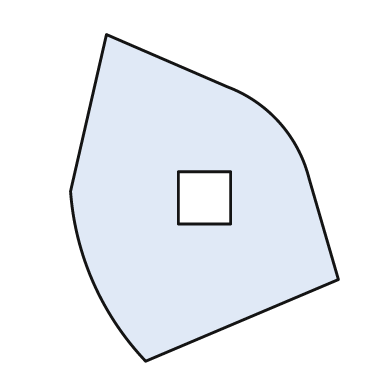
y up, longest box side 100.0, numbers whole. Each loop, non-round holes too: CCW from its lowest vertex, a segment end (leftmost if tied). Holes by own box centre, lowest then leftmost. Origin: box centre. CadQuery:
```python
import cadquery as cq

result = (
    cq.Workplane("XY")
    .moveTo(-18.0, -50.0)
    .lineTo(41.0, -25.0)
    .lineTo(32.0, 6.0)
    .threePointArc((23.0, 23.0), (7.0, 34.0))
    .lineTo(-30.0, 50.0)
    .lineTo(-41.0, 2.0)
    .threePointArc((-34.0, -26.0), (-18.0, -50.0))
    .close()
    .moveTo(-8.0, -8.0)
    .lineTo(8.0, -8.0)
    .lineTo(8.0, 8.0)
    .lineTo(-8.0, 8.0)
    .close()
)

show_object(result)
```